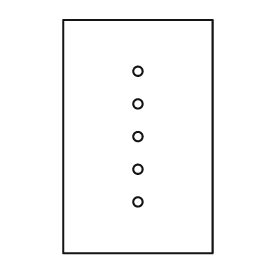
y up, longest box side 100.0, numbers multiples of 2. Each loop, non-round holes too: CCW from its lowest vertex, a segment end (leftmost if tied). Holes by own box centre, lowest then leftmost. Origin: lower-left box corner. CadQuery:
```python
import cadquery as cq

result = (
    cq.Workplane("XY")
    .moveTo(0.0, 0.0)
    .lineTo(64.0, 0.0)
    .lineTo(64.0, 100.0)
    .lineTo(0.0, 100.0)
    .close()
    .moveTo(32.0, 22.0)
    .circle(2.0)
    .moveTo(32.0, 36.0)
    .circle(2.0)
    .moveTo(32.0, 50.0)
    .circle(2.0)
    .moveTo(32.0, 64.0)
    .circle(2.0)
    .moveTo(32.0, 78.0)
    .circle(2.0)
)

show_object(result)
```